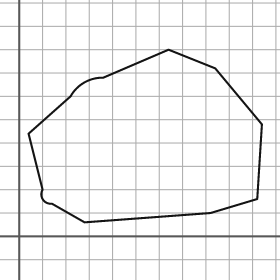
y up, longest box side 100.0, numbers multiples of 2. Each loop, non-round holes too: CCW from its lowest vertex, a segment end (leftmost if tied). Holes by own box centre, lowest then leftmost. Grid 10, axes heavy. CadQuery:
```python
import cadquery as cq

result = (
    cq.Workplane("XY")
    .moveTo(28.0, 6.0)
    .lineTo(82.0, 10.0)
    .lineTo(102.0, 16.0)
    .lineTo(104.0, 48.0)
    .lineTo(84.0, 72.0)
    .lineTo(64.0, 80.0)
    .lineTo(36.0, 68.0)
    .threePointArc((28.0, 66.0), (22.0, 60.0))
    .lineTo(4.0, 44.0)
    .lineTo(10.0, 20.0)
    .threePointArc((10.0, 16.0), (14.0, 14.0))
    .close()
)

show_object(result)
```